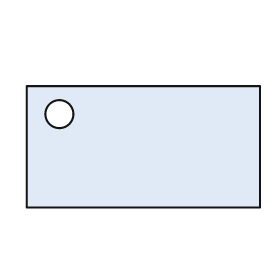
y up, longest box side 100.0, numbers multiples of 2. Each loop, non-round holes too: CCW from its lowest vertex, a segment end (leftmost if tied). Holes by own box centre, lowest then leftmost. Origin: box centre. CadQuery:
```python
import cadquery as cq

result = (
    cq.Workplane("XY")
    .moveTo(-50.0, -26.0)
    .lineTo(50.0, -26.0)
    .lineTo(50.0, 26.0)
    .lineTo(-50.0, 26.0)
    .close()
    .moveTo(-36.0, 14.0)
    .circle(6.0)
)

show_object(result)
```